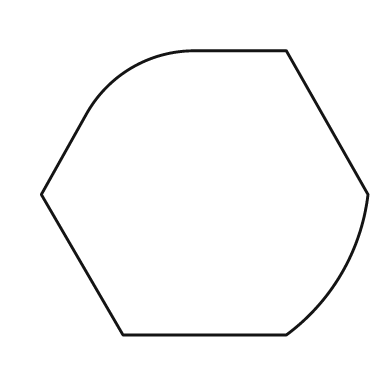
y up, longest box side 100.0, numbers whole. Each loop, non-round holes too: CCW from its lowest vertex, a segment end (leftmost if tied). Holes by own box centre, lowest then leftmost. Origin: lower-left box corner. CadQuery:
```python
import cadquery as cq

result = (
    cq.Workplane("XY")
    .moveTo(25.0, 0.0)
    .lineTo(75.0, 0.0)
    .threePointArc((92.0, 19.0), (100.0, 43.0))
    .lineTo(75.0, 87.0)
    .lineTo(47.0, 87.0)
    .threePointArc((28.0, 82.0), (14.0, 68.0))
    .lineTo(0.0, 43.0)
    .close()
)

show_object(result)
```